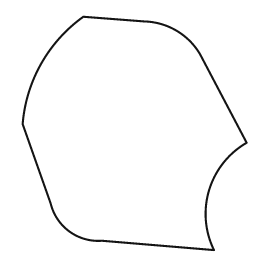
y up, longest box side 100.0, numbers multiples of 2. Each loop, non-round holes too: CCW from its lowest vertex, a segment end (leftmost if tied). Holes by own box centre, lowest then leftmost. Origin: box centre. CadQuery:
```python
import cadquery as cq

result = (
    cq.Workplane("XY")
    .moveTo(34.0, -50.0)
    .threePointArc((32.0, -24.0), (48.0, -4.0))
    .lineTo(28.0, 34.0)
    .threePointArc((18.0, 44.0), (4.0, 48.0))
    .lineTo(-22.0, 50.0)
    .threePointArc((-40.0, 30.0), (-48.0, 4.0))
    .lineTo(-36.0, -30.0)
    .threePointArc((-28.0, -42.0), (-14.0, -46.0))
    .close()
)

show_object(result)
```